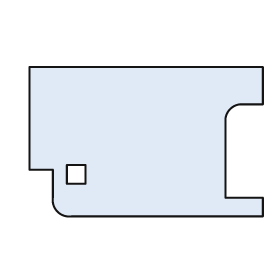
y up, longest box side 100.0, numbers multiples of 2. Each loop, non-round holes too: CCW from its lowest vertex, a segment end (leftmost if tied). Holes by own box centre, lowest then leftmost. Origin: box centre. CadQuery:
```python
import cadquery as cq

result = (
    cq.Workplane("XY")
    .moveTo(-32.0, -32.0)
    .lineTo(50.0, -32.0)
    .lineTo(50.0, -24.0)
    .lineTo(34.0, -24.0)
    .lineTo(34.0, 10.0)
    .threePointArc((36.0, 14.0), (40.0, 16.0))
    .lineTo(50.0, 16.0)
    .lineTo(50.0, 32.0)
    .lineTo(-50.0, 32.0)
    .lineTo(-50.0, -12.0)
    .lineTo(-40.0, -12.0)
    .lineTo(-40.0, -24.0)
    .threePointArc((-38.0, -30.0), (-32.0, -32.0))
    .close()
    .moveTo(-34.0, -18.0)
    .lineTo(-26.0, -18.0)
    .lineTo(-26.0, -10.0)
    .lineTo(-34.0, -10.0)
    .close()
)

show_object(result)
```